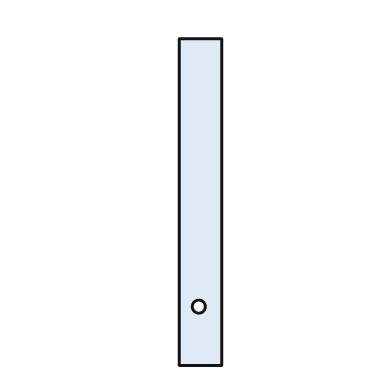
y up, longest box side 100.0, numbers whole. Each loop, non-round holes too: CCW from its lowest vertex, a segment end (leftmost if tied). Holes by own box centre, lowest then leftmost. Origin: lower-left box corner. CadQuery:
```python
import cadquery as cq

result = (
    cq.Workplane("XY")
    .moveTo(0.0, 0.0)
    .lineTo(13.0, 0.0)
    .lineTo(13.0, 100.0)
    .lineTo(0.0, 100.0)
    .close()
    .moveTo(6.0, 18.0)
    .circle(2.0)
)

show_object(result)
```